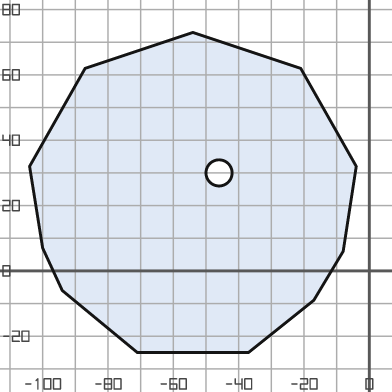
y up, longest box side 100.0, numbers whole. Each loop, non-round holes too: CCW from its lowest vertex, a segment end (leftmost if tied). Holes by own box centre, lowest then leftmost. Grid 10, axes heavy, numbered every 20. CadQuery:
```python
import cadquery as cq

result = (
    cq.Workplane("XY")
    .moveTo(-71.0, -25.0)
    .lineTo(-37.0, -25.0)
    .lineTo(-17.0, -9.0)
    .lineTo(-8.0, 6.0)
    .lineTo(-4.0, 32.0)
    .lineTo(-21.0, 62.0)
    .lineTo(-54.0, 73.0)
    .lineTo(-87.0, 62.0)
    .lineTo(-104.0, 32.0)
    .lineTo(-100.0, 7.0)
    .lineTo(-94.0, -6.0)
    .close()
    .moveTo(-46.0, 30.0)
    .circle(4.0)
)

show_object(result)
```